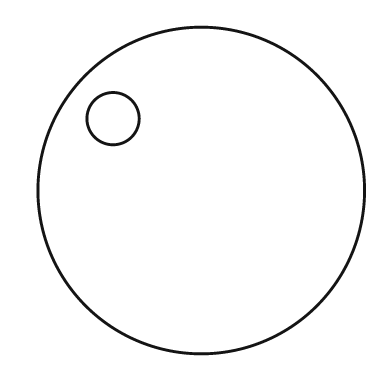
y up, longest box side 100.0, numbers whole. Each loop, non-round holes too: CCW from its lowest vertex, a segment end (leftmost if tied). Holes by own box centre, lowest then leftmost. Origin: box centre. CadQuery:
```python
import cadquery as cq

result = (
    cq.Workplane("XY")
    .moveTo(0.0, 0.0)
    .circle(50.0)
    .moveTo(-27.0, 22.0)
    .circle(8.0)
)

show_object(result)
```